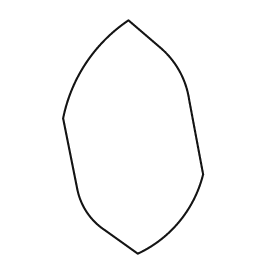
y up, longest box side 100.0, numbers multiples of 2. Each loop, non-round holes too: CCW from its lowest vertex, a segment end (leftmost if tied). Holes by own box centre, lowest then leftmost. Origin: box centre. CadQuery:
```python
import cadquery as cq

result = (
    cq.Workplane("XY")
    .moveTo(2.0, -50.0)
    .threePointArc((20.0, -36.0), (30.0, -16.0))
    .lineTo(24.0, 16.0)
    .threePointArc((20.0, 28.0), (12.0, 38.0))
    .lineTo(-2.0, 50.0)
    .threePointArc((-20.0, 32.0), (-30.0, 8.0))
    .lineTo(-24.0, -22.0)
    .threePointArc((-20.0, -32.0), (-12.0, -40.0))
    .close()
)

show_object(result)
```